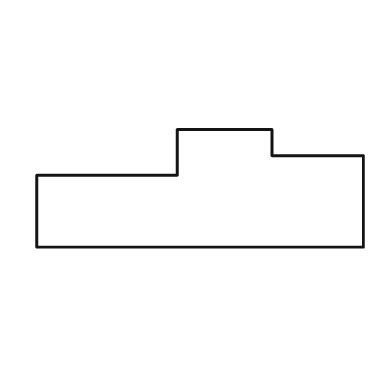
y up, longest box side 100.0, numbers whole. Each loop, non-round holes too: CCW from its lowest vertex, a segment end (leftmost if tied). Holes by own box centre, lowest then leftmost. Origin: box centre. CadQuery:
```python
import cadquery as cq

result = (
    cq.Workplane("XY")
    .moveTo(-50.0, -18.0)
    .lineTo(50.0, -18.0)
    .lineTo(50.0, 10.0)
    .lineTo(22.0, 10.0)
    .lineTo(22.0, 18.0)
    .lineTo(-7.0, 18.0)
    .lineTo(-7.0, 4.0)
    .lineTo(-50.0, 4.0)
    .close()
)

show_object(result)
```